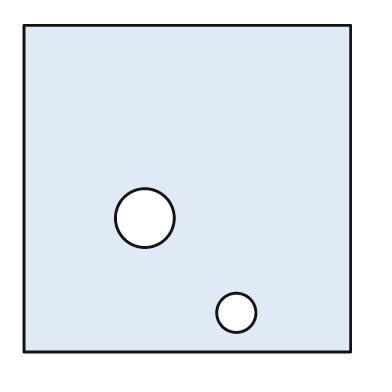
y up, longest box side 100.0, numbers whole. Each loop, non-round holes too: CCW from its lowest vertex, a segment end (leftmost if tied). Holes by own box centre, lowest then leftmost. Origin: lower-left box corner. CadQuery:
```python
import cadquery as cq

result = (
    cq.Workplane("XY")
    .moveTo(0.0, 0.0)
    .lineTo(100.0, 0.0)
    .lineTo(100.0, 100.0)
    .lineTo(0.0, 100.0)
    .close()
    .moveTo(65.0, 12.0)
    .circle(6.0)
    .moveTo(37.0, 41.0)
    .circle(9.0)
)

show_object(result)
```